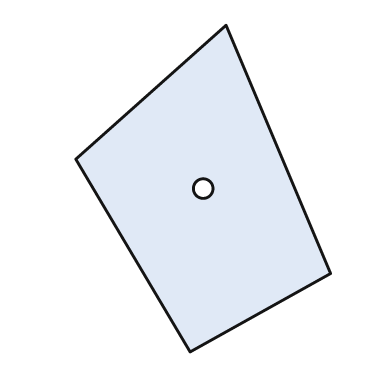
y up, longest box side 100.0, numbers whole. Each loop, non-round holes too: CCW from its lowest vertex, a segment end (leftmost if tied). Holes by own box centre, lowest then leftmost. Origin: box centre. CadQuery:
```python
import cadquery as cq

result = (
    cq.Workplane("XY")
    .moveTo(-4.0, -50.0)
    .lineTo(39.0, -26.0)
    .lineTo(7.0, 50.0)
    .lineTo(-39.0, 9.0)
    .close()
    .moveTo(0.0, 0.0)
    .circle(3.0)
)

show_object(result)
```